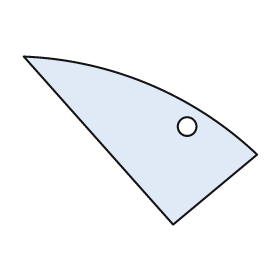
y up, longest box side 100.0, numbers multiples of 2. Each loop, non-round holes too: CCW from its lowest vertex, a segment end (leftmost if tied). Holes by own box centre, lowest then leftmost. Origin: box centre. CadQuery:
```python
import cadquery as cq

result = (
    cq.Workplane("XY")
    .moveTo(14.0, -36.0)
    .lineTo(50.0, -6.0)
    .threePointArc((4.0, 24.0), (-50.0, 36.0))
    .close()
    .moveTo(20.0, 6.0)
    .circle(4.0)
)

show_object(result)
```